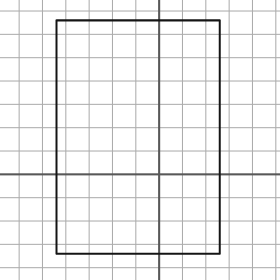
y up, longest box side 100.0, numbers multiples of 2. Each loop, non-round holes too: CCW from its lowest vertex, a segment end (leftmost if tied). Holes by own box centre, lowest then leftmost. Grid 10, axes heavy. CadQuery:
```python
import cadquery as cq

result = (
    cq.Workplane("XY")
    .moveTo(-44.0, -34.0)
    .lineTo(26.0, -34.0)
    .lineTo(26.0, 66.0)
    .lineTo(-44.0, 66.0)
    .close()
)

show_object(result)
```